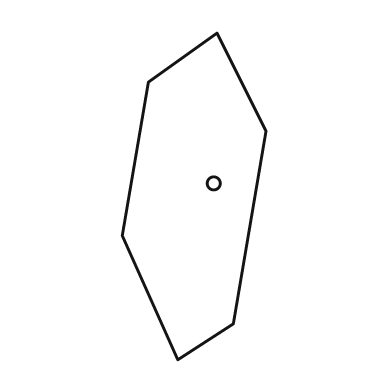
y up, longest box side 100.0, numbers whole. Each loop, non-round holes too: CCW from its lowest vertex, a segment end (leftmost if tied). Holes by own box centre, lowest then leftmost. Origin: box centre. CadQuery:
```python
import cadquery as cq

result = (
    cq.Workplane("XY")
    .moveTo(-5.0, -50.0)
    .lineTo(12.0, -39.0)
    .lineTo(22.0, 20.0)
    .lineTo(7.0, 50.0)
    .lineTo(-14.0, 35.0)
    .lineTo(-22.0, -12.0)
    .close()
    .moveTo(6.0, 4.0)
    .circle(2.0)
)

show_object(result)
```